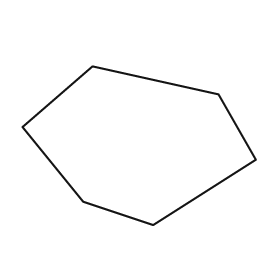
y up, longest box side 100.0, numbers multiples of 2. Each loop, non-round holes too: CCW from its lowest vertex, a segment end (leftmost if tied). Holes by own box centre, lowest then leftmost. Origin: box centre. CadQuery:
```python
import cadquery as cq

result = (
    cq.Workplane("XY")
    .moveTo(6.0, -34.0)
    .lineTo(50.0, -6.0)
    .lineTo(34.0, 22.0)
    .lineTo(-20.0, 34.0)
    .lineTo(-50.0, 8.0)
    .lineTo(-24.0, -24.0)
    .close()
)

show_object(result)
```